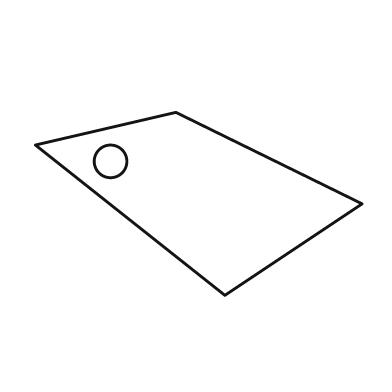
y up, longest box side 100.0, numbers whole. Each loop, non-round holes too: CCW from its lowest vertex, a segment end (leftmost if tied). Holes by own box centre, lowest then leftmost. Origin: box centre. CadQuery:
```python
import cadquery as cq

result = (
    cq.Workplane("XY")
    .moveTo(8.0, -28.0)
    .lineTo(50.0, 0.0)
    .lineTo(-7.0, 28.0)
    .lineTo(-50.0, 18.0)
    .close()
    .moveTo(-27.0, 13.0)
    .circle(5.0)
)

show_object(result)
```